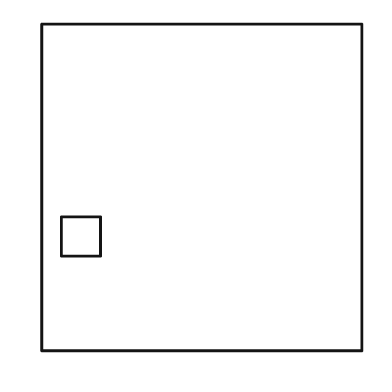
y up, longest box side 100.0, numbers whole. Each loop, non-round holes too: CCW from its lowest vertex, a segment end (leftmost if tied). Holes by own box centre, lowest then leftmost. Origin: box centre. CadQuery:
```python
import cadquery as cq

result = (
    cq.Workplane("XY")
    .moveTo(-49.0, -50.0)
    .lineTo(49.0, -50.0)
    .lineTo(49.0, 50.0)
    .lineTo(-49.0, 50.0)
    .close()
    .moveTo(-43.0, -21.0)
    .lineTo(-31.0, -21.0)
    .lineTo(-31.0, -9.0)
    .lineTo(-43.0, -9.0)
    .close()
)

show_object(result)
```